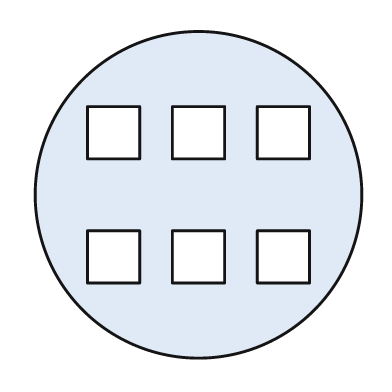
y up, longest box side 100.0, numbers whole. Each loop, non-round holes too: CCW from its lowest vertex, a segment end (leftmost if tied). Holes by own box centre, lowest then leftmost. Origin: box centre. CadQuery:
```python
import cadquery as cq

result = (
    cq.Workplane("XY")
    .moveTo(0.0, 0.0)
    .circle(50.0)
    .moveTo(-34.0, -27.0)
    .lineTo(-18.0, -27.0)
    .lineTo(-18.0, -11.0)
    .lineTo(-34.0, -11.0)
    .close()
    .moveTo(-8.0, -27.0)
    .lineTo(8.0, -27.0)
    .lineTo(8.0, -11.0)
    .lineTo(-8.0, -11.0)
    .close()
    .moveTo(18.0, -27.0)
    .lineTo(34.0, -27.0)
    .lineTo(34.0, -11.0)
    .lineTo(18.0, -11.0)
    .close()
    .moveTo(-34.0, 11.0)
    .lineTo(-18.0, 11.0)
    .lineTo(-18.0, 27.0)
    .lineTo(-34.0, 27.0)
    .close()
    .moveTo(-8.0, 11.0)
    .lineTo(8.0, 11.0)
    .lineTo(8.0, 27.0)
    .lineTo(-8.0, 27.0)
    .close()
    .moveTo(18.0, 11.0)
    .lineTo(34.0, 11.0)
    .lineTo(34.0, 27.0)
    .lineTo(18.0, 27.0)
    .close()
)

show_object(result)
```